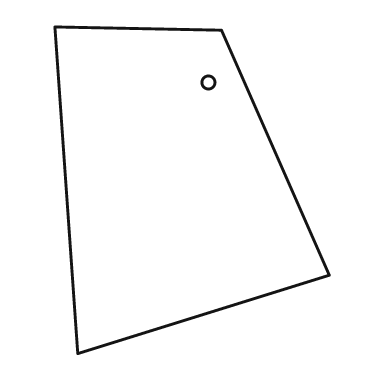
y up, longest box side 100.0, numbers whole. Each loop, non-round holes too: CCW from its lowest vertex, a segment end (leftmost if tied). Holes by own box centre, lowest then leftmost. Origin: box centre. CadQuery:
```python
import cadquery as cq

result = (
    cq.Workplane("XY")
    .moveTo(-35.0, -50.0)
    .lineTo(42.0, -26.0)
    .lineTo(9.0, 49.0)
    .lineTo(-42.0, 50.0)
    .close()
    .moveTo(5.0, 33.0)
    .circle(2.0)
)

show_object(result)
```